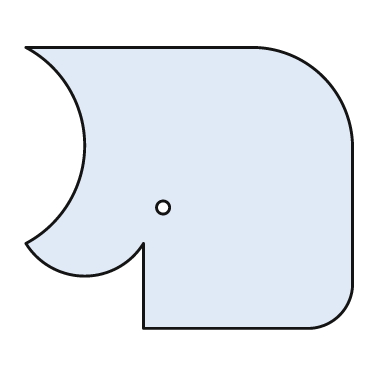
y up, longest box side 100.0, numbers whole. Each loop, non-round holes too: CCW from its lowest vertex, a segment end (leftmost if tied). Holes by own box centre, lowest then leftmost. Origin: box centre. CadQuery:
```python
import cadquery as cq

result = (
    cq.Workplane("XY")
    .moveTo(-14.0, -43.0)
    .lineTo(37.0, -43.0)
    .threePointArc((46.0, -39.0), (50.0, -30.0))
    .lineTo(50.0, 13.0)
    .threePointArc((41.0, 34.0), (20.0, 43.0))
    .lineTo(-50.0, 43.0)
    .threePointArc((-32.0, 13.0), (-50.0, -17.0))
    .threePointArc((-32.0, -27.0), (-14.0, -17.0))
    .close()
    .moveTo(-8.0, -6.0)
    .circle(2.0)
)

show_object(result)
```